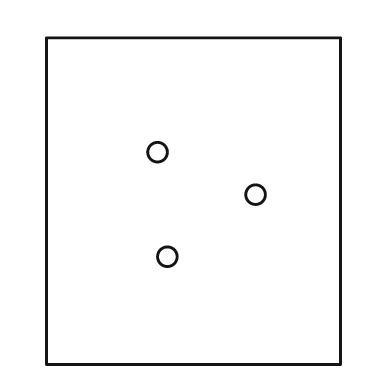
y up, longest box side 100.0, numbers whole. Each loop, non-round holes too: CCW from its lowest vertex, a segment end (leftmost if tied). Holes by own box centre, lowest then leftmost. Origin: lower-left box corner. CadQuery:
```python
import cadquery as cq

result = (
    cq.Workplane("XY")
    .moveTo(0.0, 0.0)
    .lineTo(90.0, 0.0)
    .lineTo(90.0, 100.0)
    .lineTo(0.0, 100.0)
    .close()
    .moveTo(37.0, 33.0)
    .circle(3.0)
    .moveTo(64.0, 52.0)
    .circle(3.0)
    .moveTo(34.0, 65.0)
    .circle(3.0)
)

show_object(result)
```